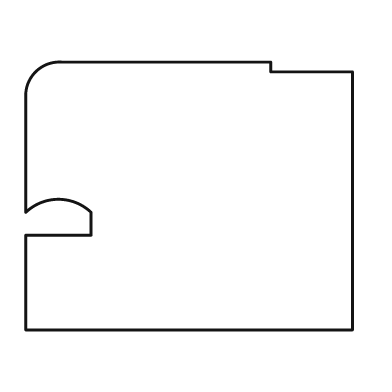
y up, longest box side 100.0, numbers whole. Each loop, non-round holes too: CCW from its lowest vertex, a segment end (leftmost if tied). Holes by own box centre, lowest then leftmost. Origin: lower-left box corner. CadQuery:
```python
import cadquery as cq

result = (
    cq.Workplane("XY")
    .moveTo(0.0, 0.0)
    .lineTo(100.0, 0.0)
    .lineTo(100.0, 79.0)
    .lineTo(75.0, 79.0)
    .lineTo(75.0, 82.0)
    .lineTo(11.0, 82.0)
    .threePointArc((3.0, 79.0), (0.0, 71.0))
    .lineTo(0.0, 36.0)
    .threePointArc((10.0, 40.0), (20.0, 36.0))
    .lineTo(20.0, 29.0)
    .lineTo(0.0, 29.0)
    .close()
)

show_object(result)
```